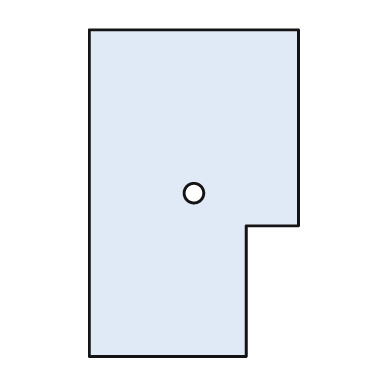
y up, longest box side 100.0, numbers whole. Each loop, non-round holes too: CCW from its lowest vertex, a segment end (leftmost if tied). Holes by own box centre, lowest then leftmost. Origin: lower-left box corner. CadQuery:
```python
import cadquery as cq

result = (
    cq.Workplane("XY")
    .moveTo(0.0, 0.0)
    .lineTo(48.0, 0.0)
    .lineTo(48.0, 40.0)
    .lineTo(64.0, 40.0)
    .lineTo(64.0, 100.0)
    .lineTo(0.0, 100.0)
    .close()
    .moveTo(32.0, 50.0)
    .circle(3.0)
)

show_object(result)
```